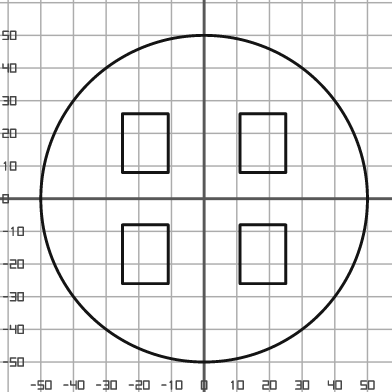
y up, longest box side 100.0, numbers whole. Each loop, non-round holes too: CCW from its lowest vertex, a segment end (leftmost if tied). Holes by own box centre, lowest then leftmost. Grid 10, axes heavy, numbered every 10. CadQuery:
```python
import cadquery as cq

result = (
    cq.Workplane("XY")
    .moveTo(0.0, 0.0)
    .circle(50.0)
    .moveTo(-25.0, -26.0)
    .lineTo(-11.0, -26.0)
    .lineTo(-11.0, -8.0)
    .lineTo(-25.0, -8.0)
    .close()
    .moveTo(11.0, -26.0)
    .lineTo(25.0, -26.0)
    .lineTo(25.0, -8.0)
    .lineTo(11.0, -8.0)
    .close()
    .moveTo(-25.0, 8.0)
    .lineTo(-11.0, 8.0)
    .lineTo(-11.0, 26.0)
    .lineTo(-25.0, 26.0)
    .close()
    .moveTo(11.0, 8.0)
    .lineTo(25.0, 8.0)
    .lineTo(25.0, 26.0)
    .lineTo(11.0, 26.0)
    .close()
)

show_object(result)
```